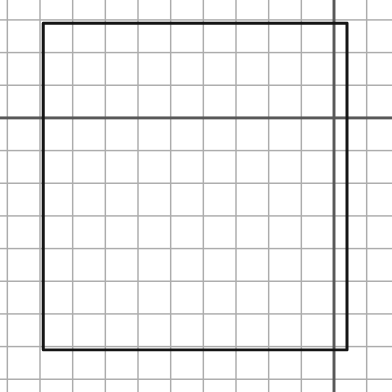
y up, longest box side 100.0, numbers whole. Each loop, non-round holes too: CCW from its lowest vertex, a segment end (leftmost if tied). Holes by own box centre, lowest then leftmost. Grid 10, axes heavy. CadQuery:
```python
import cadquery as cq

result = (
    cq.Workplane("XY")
    .moveTo(-89.0, -71.0)
    .lineTo(4.0, -71.0)
    .lineTo(4.0, 29.0)
    .lineTo(-89.0, 29.0)
    .close()
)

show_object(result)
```